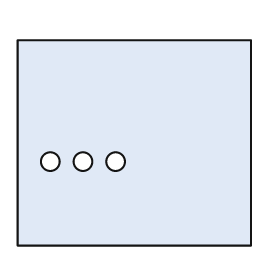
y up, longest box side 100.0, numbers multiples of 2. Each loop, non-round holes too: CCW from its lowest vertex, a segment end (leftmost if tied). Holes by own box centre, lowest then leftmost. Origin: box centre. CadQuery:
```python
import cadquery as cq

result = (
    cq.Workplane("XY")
    .moveTo(-50.0, -44.0)
    .lineTo(50.0, -44.0)
    .lineTo(50.0, 44.0)
    .lineTo(-50.0, 44.0)
    .close()
    .moveTo(-36.0, -8.0)
    .circle(4.0)
    .moveTo(-22.0, -8.0)
    .circle(4.0)
    .moveTo(-8.0, -8.0)
    .circle(4.0)
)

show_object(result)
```